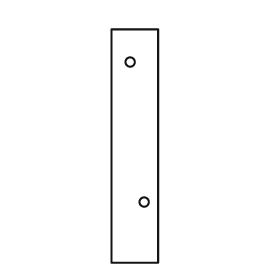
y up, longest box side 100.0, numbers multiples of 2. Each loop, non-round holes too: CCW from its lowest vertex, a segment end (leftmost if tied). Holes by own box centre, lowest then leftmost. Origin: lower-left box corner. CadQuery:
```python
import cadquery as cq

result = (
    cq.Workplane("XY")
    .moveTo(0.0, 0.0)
    .lineTo(20.0, 0.0)
    .lineTo(20.0, 100.0)
    .lineTo(0.0, 100.0)
    .close()
    .moveTo(14.0, 26.0)
    .circle(2.0)
    .moveTo(8.0, 86.0)
    .circle(2.0)
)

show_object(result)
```